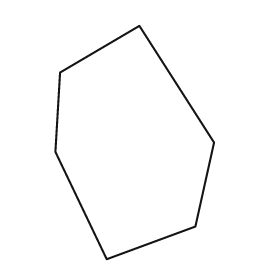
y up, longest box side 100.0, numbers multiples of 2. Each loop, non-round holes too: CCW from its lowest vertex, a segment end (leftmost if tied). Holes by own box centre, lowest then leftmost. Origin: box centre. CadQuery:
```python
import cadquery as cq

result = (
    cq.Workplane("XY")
    .moveTo(-12.0, -50.0)
    .lineTo(26.0, -36.0)
    .lineTo(34.0, 0.0)
    .lineTo(2.0, 50.0)
    .lineTo(-32.0, 30.0)
    .lineTo(-34.0, -4.0)
    .close()
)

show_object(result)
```